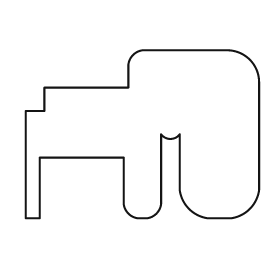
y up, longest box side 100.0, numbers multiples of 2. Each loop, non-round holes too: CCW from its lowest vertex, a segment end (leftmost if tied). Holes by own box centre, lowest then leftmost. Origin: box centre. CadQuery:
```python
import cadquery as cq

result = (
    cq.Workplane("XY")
    .moveTo(-50.0, -36.0)
    .lineTo(-44.0, -36.0)
    .lineTo(-44.0, -10.0)
    .lineTo(-8.0, -10.0)
    .lineTo(-8.0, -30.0)
    .threePointArc((-6.0, -34.0), (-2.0, -36.0))
    .lineTo(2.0, -36.0)
    .threePointArc((6.0, -34.0), (8.0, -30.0))
    .lineTo(8.0, 0.0)
    .threePointArc((12.0, -2.0), (16.0, 0.0))
    .lineTo(16.0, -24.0)
    .threePointArc((20.0, -32.0), (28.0, -36.0))
    .lineTo(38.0, -36.0)
    .threePointArc((46.0, -32.0), (50.0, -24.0))
    .lineTo(50.0, 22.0)
    .threePointArc((46.0, 32.0), (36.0, 36.0))
    .lineTo(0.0, 36.0)
    .threePointArc((-4.0, 34.0), (-6.0, 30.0))
    .lineTo(-6.0, 20.0)
    .lineTo(-42.0, 20.0)
    .lineTo(-42.0, 10.0)
    .lineTo(-50.0, 10.0)
    .close()
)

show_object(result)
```